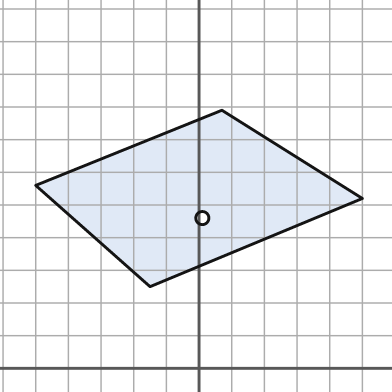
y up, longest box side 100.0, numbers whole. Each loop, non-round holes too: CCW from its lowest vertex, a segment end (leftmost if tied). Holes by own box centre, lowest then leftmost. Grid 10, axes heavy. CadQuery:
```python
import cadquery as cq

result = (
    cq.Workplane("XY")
    .moveTo(-15.0, 25.0)
    .lineTo(50.0, 52.0)
    .lineTo(7.0, 79.0)
    .lineTo(-50.0, 56.0)
    .close()
    .moveTo(1.0, 46.0)
    .circle(2.0)
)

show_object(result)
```